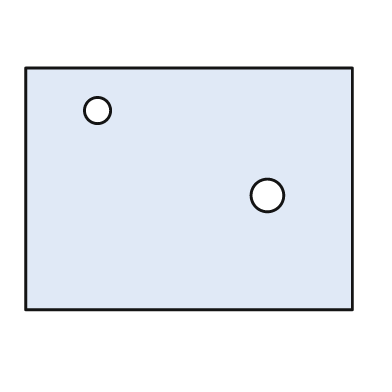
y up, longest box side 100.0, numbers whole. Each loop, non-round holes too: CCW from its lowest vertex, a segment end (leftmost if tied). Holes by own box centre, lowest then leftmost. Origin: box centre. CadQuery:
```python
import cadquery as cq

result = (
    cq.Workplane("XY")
    .moveTo(-50.0, -37.0)
    .lineTo(50.0, -37.0)
    .lineTo(50.0, 37.0)
    .lineTo(-50.0, 37.0)
    .close()
    .moveTo(24.0, -2.0)
    .circle(5.0)
    .moveTo(-28.0, 24.0)
    .circle(4.0)
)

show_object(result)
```